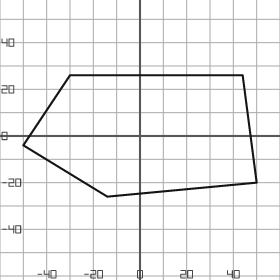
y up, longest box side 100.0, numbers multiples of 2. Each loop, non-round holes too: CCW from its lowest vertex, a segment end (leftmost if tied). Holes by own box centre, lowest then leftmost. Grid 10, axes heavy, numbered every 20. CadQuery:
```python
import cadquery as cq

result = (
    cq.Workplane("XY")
    .moveTo(-14.0, -26.0)
    .lineTo(50.0, -20.0)
    .lineTo(44.0, 26.0)
    .lineTo(-30.0, 26.0)
    .lineTo(-50.0, -4.0)
    .close()
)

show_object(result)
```